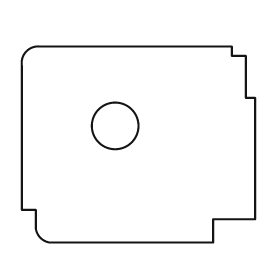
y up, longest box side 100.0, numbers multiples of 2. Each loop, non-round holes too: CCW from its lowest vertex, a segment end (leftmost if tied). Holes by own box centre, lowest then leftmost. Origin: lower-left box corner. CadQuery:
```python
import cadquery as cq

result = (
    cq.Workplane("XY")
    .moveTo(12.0, 0.0)
    .lineTo(82.0, 0.0)
    .lineTo(82.0, 10.0)
    .lineTo(100.0, 10.0)
    .lineTo(100.0, 62.0)
    .lineTo(96.0, 62.0)
    .lineTo(96.0, 80.0)
    .lineTo(90.0, 80.0)
    .lineTo(90.0, 84.0)
    .lineTo(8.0, 84.0)
    .threePointArc((2.0, 82.0), (0.0, 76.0))
    .lineTo(0.0, 14.0)
    .lineTo(6.0, 14.0)
    .lineTo(6.0, 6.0)
    .threePointArc((8.0, 2.0), (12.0, 0.0))
    .close()
    .moveTo(40.0, 50.0)
    .circle(10.0)
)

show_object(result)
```